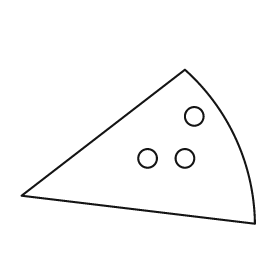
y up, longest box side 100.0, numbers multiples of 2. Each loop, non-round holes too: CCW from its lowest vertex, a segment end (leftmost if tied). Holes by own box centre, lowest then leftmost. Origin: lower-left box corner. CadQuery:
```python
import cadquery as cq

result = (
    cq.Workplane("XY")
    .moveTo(100.0, 0.0)
    .threePointArc((92.0, 36.0), (70.0, 66.0))
    .lineTo(0.0, 12.0)
    .close()
    .moveTo(54.0, 28.0)
    .circle(4.0)
    .moveTo(70.0, 28.0)
    .circle(4.0)
    .moveTo(74.0, 46.0)
    .circle(4.0)
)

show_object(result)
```